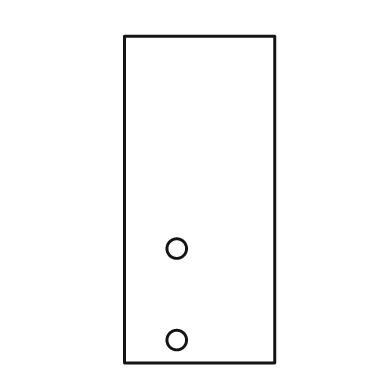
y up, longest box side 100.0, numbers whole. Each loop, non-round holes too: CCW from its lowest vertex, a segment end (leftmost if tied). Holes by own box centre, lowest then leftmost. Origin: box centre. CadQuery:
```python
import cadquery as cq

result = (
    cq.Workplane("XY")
    .moveTo(-23.0, -50.0)
    .lineTo(23.0, -50.0)
    .lineTo(23.0, 50.0)
    .lineTo(-23.0, 50.0)
    .close()
    .moveTo(-7.0, -43.0)
    .circle(3.0)
    .moveTo(-7.0, -15.0)
    .circle(3.0)
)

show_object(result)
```